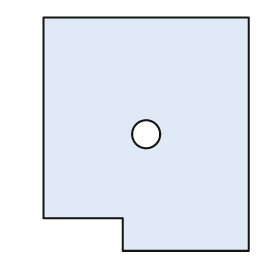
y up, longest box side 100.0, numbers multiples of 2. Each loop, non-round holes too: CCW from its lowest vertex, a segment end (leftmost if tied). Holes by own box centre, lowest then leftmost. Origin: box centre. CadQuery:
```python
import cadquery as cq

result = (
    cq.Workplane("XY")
    .moveTo(-10.0, -50.0)
    .lineTo(44.0, -50.0)
    .lineTo(44.0, 50.0)
    .lineTo(-44.0, 50.0)
    .lineTo(-44.0, -36.0)
    .lineTo(-10.0, -36.0)
    .close()
    .moveTo(0.0, 0.0)
    .circle(6.0)
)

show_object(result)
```